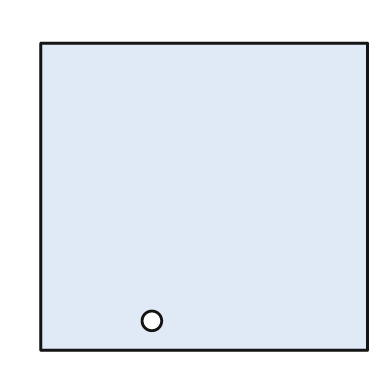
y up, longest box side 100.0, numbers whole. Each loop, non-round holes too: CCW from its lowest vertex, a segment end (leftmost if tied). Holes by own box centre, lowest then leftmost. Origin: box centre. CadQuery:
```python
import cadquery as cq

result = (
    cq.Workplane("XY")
    .moveTo(-50.0, -47.0)
    .lineTo(50.0, -47.0)
    .lineTo(50.0, 47.0)
    .lineTo(-50.0, 47.0)
    .close()
    .moveTo(-16.0, -38.0)
    .circle(3.0)
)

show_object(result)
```